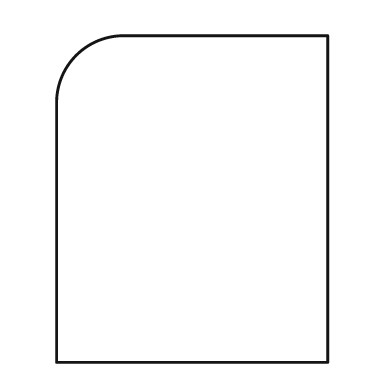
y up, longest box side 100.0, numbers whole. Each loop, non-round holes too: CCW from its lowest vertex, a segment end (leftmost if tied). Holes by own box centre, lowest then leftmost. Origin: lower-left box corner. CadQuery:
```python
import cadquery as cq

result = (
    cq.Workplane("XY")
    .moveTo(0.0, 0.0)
    .lineTo(83.0, 0.0)
    .lineTo(83.0, 100.0)
    .lineTo(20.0, 100.0)
    .threePointArc((6.0, 94.0), (0.0, 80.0))
    .close()
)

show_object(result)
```